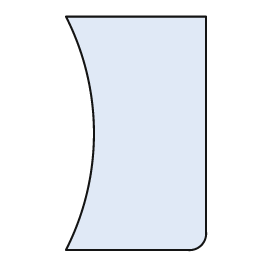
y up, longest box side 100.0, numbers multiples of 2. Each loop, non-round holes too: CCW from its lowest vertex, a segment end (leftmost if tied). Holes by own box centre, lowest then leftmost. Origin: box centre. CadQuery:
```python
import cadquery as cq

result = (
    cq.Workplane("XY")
    .moveTo(-30.0, -50.0)
    .lineTo(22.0, -50.0)
    .threePointArc((28.0, -48.0), (30.0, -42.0))
    .lineTo(30.0, 50.0)
    .lineTo(-30.0, 50.0)
    .threePointArc((-18.0, 0.0), (-30.0, -50.0))
    .close()
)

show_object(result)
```